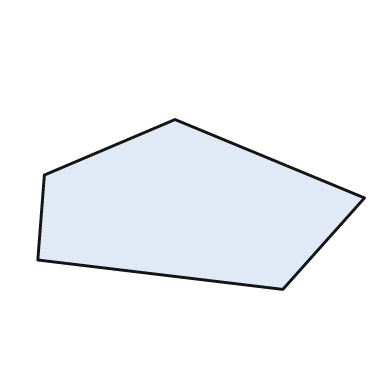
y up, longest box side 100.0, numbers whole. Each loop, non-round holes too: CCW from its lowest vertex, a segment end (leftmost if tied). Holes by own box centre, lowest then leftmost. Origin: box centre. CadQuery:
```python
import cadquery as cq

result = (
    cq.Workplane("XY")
    .moveTo(25.0, -26.0)
    .lineTo(50.0, 2.0)
    .lineTo(-8.0, 26.0)
    .lineTo(-48.0, 9.0)
    .lineTo(-50.0, -17.0)
    .close()
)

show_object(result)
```